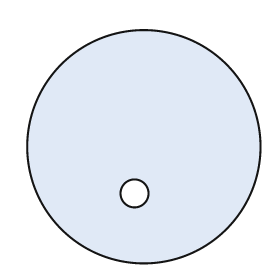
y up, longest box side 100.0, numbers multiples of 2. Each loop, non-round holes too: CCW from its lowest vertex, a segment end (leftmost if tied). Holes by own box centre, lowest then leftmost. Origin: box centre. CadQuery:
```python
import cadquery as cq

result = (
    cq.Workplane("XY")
    .moveTo(0.0, 0.0)
    .circle(50.0)
    .moveTo(-4.0, -20.0)
    .circle(6.0)
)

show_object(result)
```